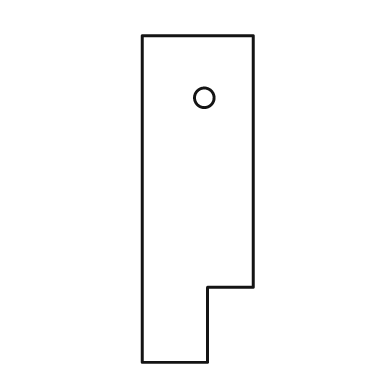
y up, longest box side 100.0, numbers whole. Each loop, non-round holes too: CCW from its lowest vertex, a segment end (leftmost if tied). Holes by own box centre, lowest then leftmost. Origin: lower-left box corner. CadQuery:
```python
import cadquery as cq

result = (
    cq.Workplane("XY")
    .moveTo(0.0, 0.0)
    .lineTo(20.0, 0.0)
    .lineTo(20.0, 23.0)
    .lineTo(34.0, 23.0)
    .lineTo(34.0, 100.0)
    .lineTo(0.0, 100.0)
    .close()
    .moveTo(19.0, 81.0)
    .circle(3.0)
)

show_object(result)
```